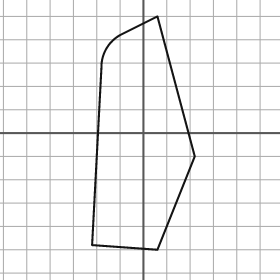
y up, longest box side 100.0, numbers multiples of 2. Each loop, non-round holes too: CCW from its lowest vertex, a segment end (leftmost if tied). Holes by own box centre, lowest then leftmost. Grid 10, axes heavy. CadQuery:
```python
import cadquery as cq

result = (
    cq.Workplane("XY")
    .moveTo(6.0, -50.0)
    .lineTo(22.0, -10.0)
    .lineTo(6.0, 50.0)
    .lineTo(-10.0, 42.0)
    .threePointArc((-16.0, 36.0), (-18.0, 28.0))
    .lineTo(-22.0, -48.0)
    .close()
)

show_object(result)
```